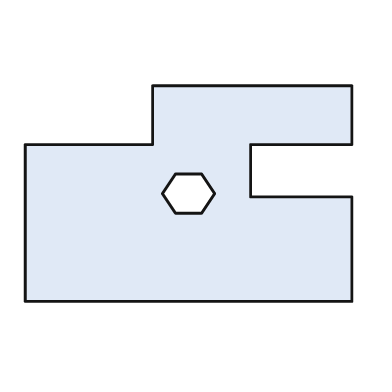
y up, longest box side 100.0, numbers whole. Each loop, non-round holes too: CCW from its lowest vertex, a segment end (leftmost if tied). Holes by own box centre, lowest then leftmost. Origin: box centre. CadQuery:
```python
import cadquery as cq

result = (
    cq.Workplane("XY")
    .moveTo(-50.0, -33.0)
    .lineTo(50.0, -33.0)
    .lineTo(50.0, -1.0)
    .lineTo(19.0, -1.0)
    .lineTo(19.0, 15.0)
    .lineTo(50.0, 15.0)
    .lineTo(50.0, 33.0)
    .lineTo(-11.0, 33.0)
    .lineTo(-11.0, 15.0)
    .lineTo(-50.0, 15.0)
    .close()
    .moveTo(-4.0, -6.0)
    .lineTo(4.0, -6.0)
    .lineTo(8.0, 0.0)
    .lineTo(4.0, 6.0)
    .lineTo(-4.0, 6.0)
    .lineTo(-8.0, 0.0)
    .close()
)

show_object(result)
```